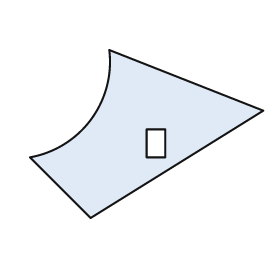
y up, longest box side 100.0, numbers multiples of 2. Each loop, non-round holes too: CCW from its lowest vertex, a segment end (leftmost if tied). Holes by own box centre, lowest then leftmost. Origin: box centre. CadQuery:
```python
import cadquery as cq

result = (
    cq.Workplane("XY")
    .moveTo(-24.0, -36.0)
    .lineTo(50.0, 10.0)
    .lineTo(-16.0, 36.0)
    .threePointArc((-24.0, 6.0), (-50.0, -10.0))
    .close()
    .moveTo(0.0, -10.0)
    .lineTo(8.0, -10.0)
    .lineTo(8.0, 2.0)
    .lineTo(0.0, 2.0)
    .close()
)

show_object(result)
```